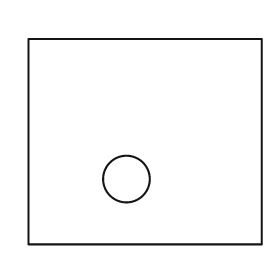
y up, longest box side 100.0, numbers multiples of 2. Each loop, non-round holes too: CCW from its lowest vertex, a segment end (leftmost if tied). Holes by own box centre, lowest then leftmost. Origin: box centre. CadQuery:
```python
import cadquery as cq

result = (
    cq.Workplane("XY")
    .moveTo(-50.0, -44.0)
    .lineTo(50.0, -44.0)
    .lineTo(50.0, 44.0)
    .lineTo(-50.0, 44.0)
    .close()
    .moveTo(-8.0, -16.0)
    .circle(10.0)
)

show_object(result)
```